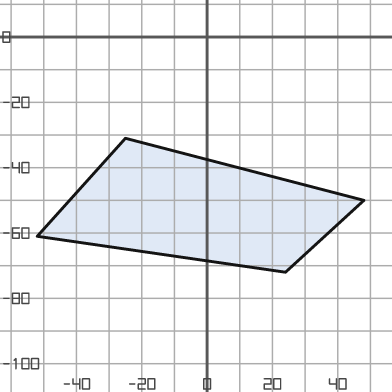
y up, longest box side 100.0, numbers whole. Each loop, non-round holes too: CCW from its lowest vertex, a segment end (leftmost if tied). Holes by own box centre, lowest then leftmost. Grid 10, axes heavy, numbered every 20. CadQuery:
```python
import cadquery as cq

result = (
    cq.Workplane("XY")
    .moveTo(24.0, -72.0)
    .lineTo(48.0, -50.0)
    .lineTo(-25.0, -31.0)
    .lineTo(-52.0, -61.0)
    .close()
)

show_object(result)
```